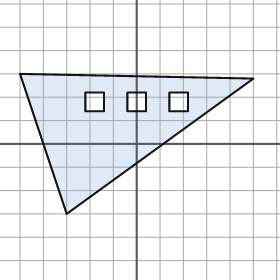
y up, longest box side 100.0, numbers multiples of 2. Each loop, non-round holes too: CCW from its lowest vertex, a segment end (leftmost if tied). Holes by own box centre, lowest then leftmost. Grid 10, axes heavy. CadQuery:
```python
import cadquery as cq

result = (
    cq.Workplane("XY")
    .moveTo(-30.0, -30.0)
    .lineTo(50.0, 28.0)
    .lineTo(-50.0, 30.0)
    .close()
    .moveTo(-22.0, 14.0)
    .lineTo(-14.0, 14.0)
    .lineTo(-14.0, 22.0)
    .lineTo(-22.0, 22.0)
    .close()
    .moveTo(-4.0, 14.0)
    .lineTo(4.0, 14.0)
    .lineTo(4.0, 22.0)
    .lineTo(-4.0, 22.0)
    .close()
    .moveTo(14.0, 14.0)
    .lineTo(22.0, 14.0)
    .lineTo(22.0, 22.0)
    .lineTo(14.0, 22.0)
    .close()
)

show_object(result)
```